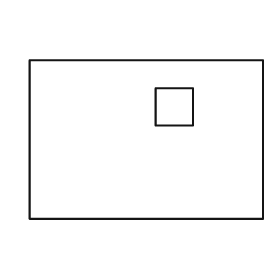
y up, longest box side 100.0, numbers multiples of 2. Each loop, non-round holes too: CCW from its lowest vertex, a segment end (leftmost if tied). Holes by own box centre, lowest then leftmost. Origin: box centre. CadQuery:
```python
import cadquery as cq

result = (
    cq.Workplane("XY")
    .moveTo(-50.0, -34.0)
    .lineTo(50.0, -34.0)
    .lineTo(50.0, 34.0)
    .lineTo(-50.0, 34.0)
    .close()
    .moveTo(4.0, 6.0)
    .lineTo(20.0, 6.0)
    .lineTo(20.0, 22.0)
    .lineTo(4.0, 22.0)
    .close()
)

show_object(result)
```